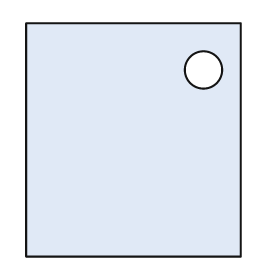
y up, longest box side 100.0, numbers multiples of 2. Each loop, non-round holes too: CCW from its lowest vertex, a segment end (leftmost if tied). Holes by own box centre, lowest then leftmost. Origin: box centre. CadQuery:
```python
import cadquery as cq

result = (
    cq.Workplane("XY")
    .moveTo(-46.0, -50.0)
    .lineTo(46.0, -50.0)
    .lineTo(46.0, 50.0)
    .lineTo(-46.0, 50.0)
    .close()
    .moveTo(30.0, 30.0)
    .circle(8.0)
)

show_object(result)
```